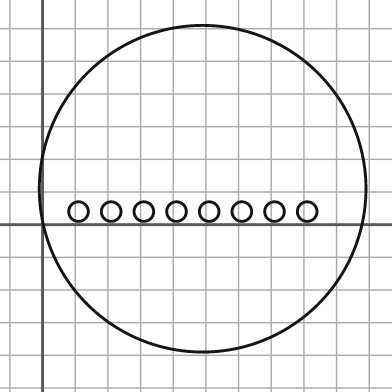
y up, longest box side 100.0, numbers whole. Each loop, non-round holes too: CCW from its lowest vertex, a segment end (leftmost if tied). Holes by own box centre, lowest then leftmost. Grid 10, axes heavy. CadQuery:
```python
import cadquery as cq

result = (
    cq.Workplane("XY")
    .moveTo(49.0, 11.0)
    .circle(50.0)
    .moveTo(11.0, 4.0)
    .circle(3.0)
    .moveTo(21.0, 4.0)
    .circle(3.0)
    .moveTo(31.0, 4.0)
    .circle(3.0)
    .moveTo(41.0, 4.0)
    .circle(3.0)
    .moveTo(51.0, 4.0)
    .circle(3.0)
    .moveTo(61.0, 4.0)
    .circle(3.0)
    .moveTo(71.0, 4.0)
    .circle(3.0)
    .moveTo(81.0, 4.0)
    .circle(3.0)
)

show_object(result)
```